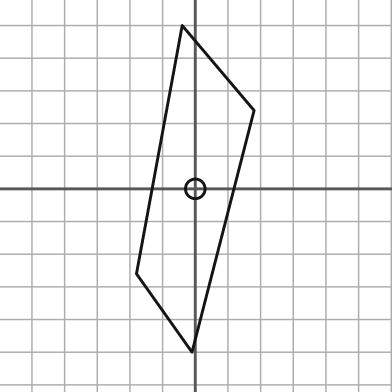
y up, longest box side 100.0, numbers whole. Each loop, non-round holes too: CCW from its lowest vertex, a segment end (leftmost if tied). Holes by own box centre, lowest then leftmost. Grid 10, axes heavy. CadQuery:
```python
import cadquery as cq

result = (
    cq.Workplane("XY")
    .moveTo(-1.0, -50.0)
    .lineTo(18.0, 24.0)
    .lineTo(-4.0, 50.0)
    .lineTo(-18.0, -26.0)
    .close()
    .moveTo(0.0, 0.0)
    .circle(3.0)
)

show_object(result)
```